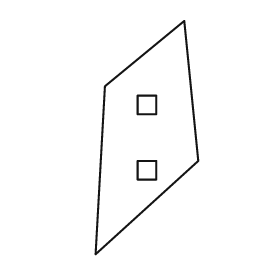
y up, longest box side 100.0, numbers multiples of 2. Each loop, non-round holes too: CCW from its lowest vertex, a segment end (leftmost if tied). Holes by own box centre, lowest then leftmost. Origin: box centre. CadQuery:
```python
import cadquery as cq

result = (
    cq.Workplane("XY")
    .moveTo(-22.0, -50.0)
    .lineTo(22.0, -10.0)
    .lineTo(16.0, 50.0)
    .lineTo(-18.0, 22.0)
    .close()
    .moveTo(-4.0, -18.0)
    .lineTo(4.0, -18.0)
    .lineTo(4.0, -10.0)
    .lineTo(-4.0, -10.0)
    .close()
    .moveTo(-4.0, 10.0)
    .lineTo(4.0, 10.0)
    .lineTo(4.0, 18.0)
    .lineTo(-4.0, 18.0)
    .close()
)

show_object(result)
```